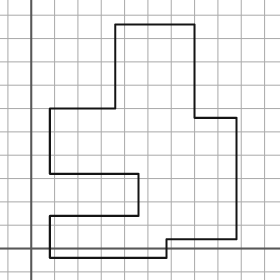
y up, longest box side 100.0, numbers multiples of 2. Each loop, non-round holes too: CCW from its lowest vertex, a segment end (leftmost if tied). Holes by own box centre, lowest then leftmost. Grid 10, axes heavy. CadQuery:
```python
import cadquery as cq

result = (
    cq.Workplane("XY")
    .moveTo(8.0, -4.0)
    .lineTo(58.0, -4.0)
    .lineTo(58.0, 4.0)
    .lineTo(88.0, 4.0)
    .lineTo(88.0, 56.0)
    .lineTo(70.0, 56.0)
    .lineTo(70.0, 96.0)
    .lineTo(36.0, 96.0)
    .lineTo(36.0, 60.0)
    .lineTo(8.0, 60.0)
    .lineTo(8.0, 32.0)
    .lineTo(46.0, 32.0)
    .lineTo(46.0, 14.0)
    .lineTo(8.0, 14.0)
    .close()
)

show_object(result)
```